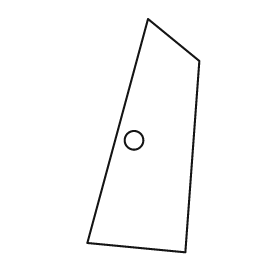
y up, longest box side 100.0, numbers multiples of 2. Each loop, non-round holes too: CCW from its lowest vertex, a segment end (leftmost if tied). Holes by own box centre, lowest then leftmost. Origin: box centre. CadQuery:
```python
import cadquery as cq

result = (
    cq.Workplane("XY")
    .moveTo(18.0, -50.0)
    .lineTo(24.0, 32.0)
    .lineTo(2.0, 50.0)
    .lineTo(-24.0, -46.0)
    .close()
    .moveTo(-4.0, -2.0)
    .circle(4.0)
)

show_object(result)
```